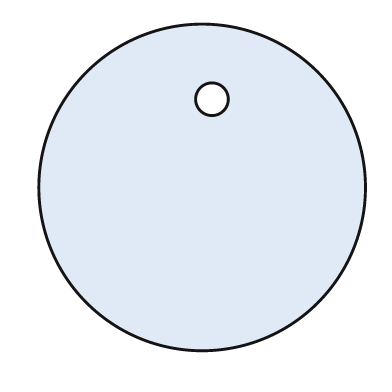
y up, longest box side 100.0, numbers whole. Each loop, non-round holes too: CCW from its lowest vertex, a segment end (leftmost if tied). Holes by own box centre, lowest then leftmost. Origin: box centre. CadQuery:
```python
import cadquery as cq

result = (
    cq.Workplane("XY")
    .moveTo(0.0, 0.0)
    .circle(50.0)
    .moveTo(3.0, 27.0)
    .circle(5.0)
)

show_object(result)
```